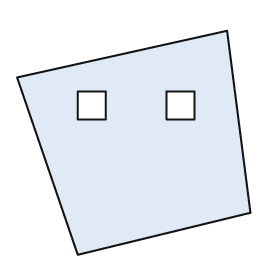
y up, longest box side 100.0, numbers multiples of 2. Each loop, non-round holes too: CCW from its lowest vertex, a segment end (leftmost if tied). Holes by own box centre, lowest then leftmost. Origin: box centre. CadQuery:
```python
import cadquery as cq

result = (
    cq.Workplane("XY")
    .moveTo(-24.0, -48.0)
    .lineTo(50.0, -30.0)
    .lineTo(40.0, 48.0)
    .lineTo(-50.0, 28.0)
    .close()
    .moveTo(-24.0, 10.0)
    .lineTo(-12.0, 10.0)
    .lineTo(-12.0, 22.0)
    .lineTo(-24.0, 22.0)
    .close()
    .moveTo(14.0, 10.0)
    .lineTo(26.0, 10.0)
    .lineTo(26.0, 22.0)
    .lineTo(14.0, 22.0)
    .close()
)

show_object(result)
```